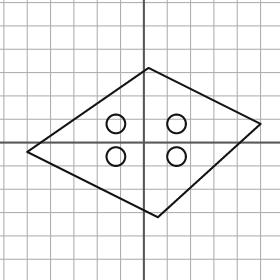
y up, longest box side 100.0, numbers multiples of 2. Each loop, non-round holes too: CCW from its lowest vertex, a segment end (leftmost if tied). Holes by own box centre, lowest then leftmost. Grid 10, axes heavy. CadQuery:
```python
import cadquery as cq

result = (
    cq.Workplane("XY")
    .moveTo(6.0, -32.0)
    .lineTo(50.0, 8.0)
    .lineTo(2.0, 32.0)
    .lineTo(-50.0, -4.0)
    .close()
    .moveTo(-12.0, -6.0)
    .circle(4.0)
    .moveTo(14.0, -6.0)
    .circle(4.0)
    .moveTo(-12.0, 8.0)
    .circle(4.0)
    .moveTo(14.0, 8.0)
    .circle(4.0)
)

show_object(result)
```